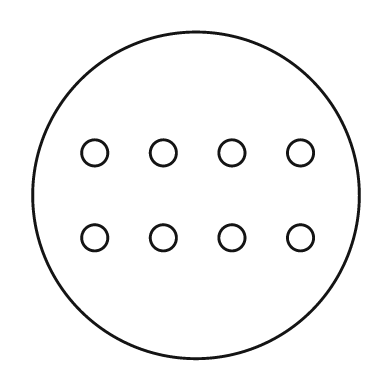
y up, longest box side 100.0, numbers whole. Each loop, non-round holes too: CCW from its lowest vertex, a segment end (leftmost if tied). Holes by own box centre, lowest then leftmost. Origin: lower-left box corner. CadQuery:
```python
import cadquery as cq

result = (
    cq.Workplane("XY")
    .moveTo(50.0, 50.0)
    .circle(50.0)
    .moveTo(19.0, 37.0)
    .circle(4.0)
    .moveTo(40.0, 37.0)
    .circle(4.0)
    .moveTo(61.0, 37.0)
    .circle(4.0)
    .moveTo(82.0, 37.0)
    .circle(4.0)
    .moveTo(19.0, 63.0)
    .circle(4.0)
    .moveTo(40.0, 63.0)
    .circle(4.0)
    .moveTo(61.0, 63.0)
    .circle(4.0)
    .moveTo(82.0, 63.0)
    .circle(4.0)
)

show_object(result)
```